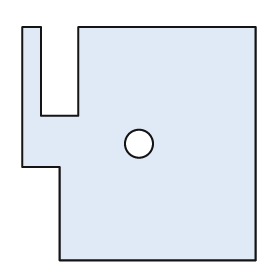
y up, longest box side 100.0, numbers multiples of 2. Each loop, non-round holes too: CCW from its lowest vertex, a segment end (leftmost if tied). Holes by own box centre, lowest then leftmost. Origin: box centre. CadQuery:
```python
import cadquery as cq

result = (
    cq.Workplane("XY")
    .moveTo(-34.0, -50.0)
    .lineTo(50.0, -50.0)
    .lineTo(50.0, 50.0)
    .lineTo(-26.0, 50.0)
    .lineTo(-26.0, 12.0)
    .lineTo(-42.0, 12.0)
    .lineTo(-42.0, 50.0)
    .lineTo(-50.0, 50.0)
    .lineTo(-50.0, -10.0)
    .lineTo(-34.0, -10.0)
    .close()
    .moveTo(0.0, 0.0)
    .circle(6.0)
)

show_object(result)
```